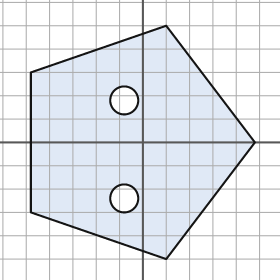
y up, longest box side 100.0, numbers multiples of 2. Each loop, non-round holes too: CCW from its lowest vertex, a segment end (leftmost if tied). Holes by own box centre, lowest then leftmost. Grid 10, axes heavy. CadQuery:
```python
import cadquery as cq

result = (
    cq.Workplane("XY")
    .moveTo(10.0, -50.0)
    .lineTo(48.0, 0.0)
    .lineTo(10.0, 50.0)
    .lineTo(-48.0, 30.0)
    .lineTo(-48.0, -30.0)
    .close()
    .moveTo(-8.0, -24.0)
    .circle(6.0)
    .moveTo(-8.0, 18.0)
    .circle(6.0)
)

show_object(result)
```